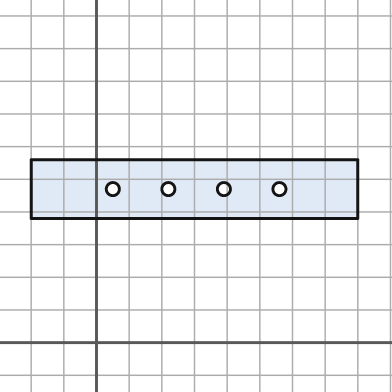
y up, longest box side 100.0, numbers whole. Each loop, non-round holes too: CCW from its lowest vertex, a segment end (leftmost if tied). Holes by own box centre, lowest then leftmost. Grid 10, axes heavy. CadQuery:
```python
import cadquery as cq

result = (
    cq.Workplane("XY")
    .moveTo(-20.0, 38.0)
    .lineTo(80.0, 38.0)
    .lineTo(80.0, 56.0)
    .lineTo(-20.0, 56.0)
    .close()
    .moveTo(5.0, 47.0)
    .circle(2.0)
    .moveTo(22.0, 47.0)
    .circle(2.0)
    .moveTo(39.0, 47.0)
    .circle(2.0)
    .moveTo(56.0, 47.0)
    .circle(2.0)
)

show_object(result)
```